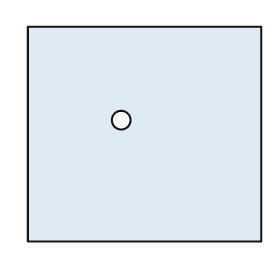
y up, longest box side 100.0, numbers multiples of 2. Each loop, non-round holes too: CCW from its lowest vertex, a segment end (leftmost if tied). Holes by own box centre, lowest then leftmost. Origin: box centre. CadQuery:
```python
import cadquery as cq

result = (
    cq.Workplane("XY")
    .moveTo(-50.0, -46.0)
    .lineTo(50.0, -46.0)
    .lineTo(50.0, 46.0)
    .lineTo(-50.0, 46.0)
    .close()
    .moveTo(-10.0, 6.0)
    .circle(4.0)
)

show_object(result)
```